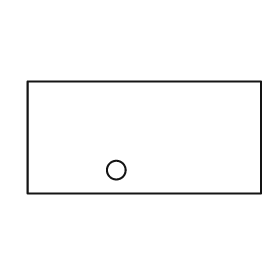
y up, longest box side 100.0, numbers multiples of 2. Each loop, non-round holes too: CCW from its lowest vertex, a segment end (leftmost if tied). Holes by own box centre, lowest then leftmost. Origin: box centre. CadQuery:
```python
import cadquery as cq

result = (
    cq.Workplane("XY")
    .moveTo(-50.0, -24.0)
    .lineTo(50.0, -24.0)
    .lineTo(50.0, 24.0)
    .lineTo(-50.0, 24.0)
    .close()
    .moveTo(-12.0, -14.0)
    .circle(4.0)
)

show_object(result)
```